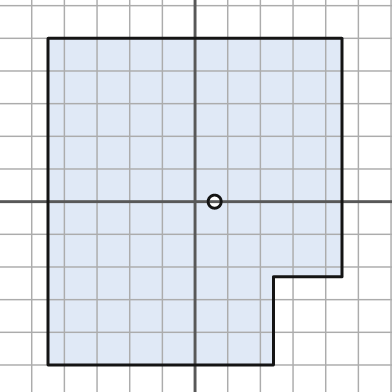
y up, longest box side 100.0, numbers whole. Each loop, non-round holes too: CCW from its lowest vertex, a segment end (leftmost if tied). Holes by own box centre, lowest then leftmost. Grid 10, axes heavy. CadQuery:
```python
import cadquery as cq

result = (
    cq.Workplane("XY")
    .moveTo(-45.0, -50.0)
    .lineTo(24.0, -50.0)
    .lineTo(24.0, -23.0)
    .lineTo(45.0, -23.0)
    .lineTo(45.0, 50.0)
    .lineTo(-45.0, 50.0)
    .close()
    .moveTo(6.0, 0.0)
    .circle(2.0)
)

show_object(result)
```